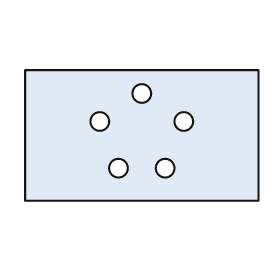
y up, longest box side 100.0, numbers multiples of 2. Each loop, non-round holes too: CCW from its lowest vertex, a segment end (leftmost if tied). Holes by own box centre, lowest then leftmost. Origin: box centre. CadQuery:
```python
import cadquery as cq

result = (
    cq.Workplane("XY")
    .moveTo(-50.0, -28.0)
    .lineTo(50.0, -28.0)
    .lineTo(50.0, 28.0)
    .lineTo(-50.0, 28.0)
    .close()
    .moveTo(-10.0, -14.0)
    .circle(4.0)
    .moveTo(10.0, -14.0)
    .circle(4.0)
    .moveTo(-18.0, 6.0)
    .circle(4.0)
    .moveTo(18.0, 6.0)
    .circle(4.0)
    .moveTo(0.0, 18.0)
    .circle(4.0)
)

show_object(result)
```